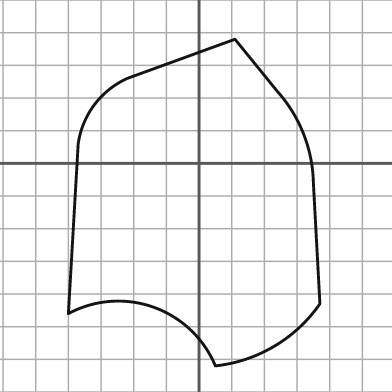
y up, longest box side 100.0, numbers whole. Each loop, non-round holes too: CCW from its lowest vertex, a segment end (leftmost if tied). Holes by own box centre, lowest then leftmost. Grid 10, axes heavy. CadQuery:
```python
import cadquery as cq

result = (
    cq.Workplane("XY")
    .moveTo(5.0, -62.0)
    .threePointArc((23.0, -56.0), (37.0, -43.0))
    .lineTo(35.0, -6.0)
    .threePointArc((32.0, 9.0), (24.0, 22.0))
    .lineTo(11.0, 38.0)
    .lineTo(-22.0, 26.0)
    .threePointArc((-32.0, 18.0), (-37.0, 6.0))
    .lineTo(-40.0, -46.0)
    .threePointArc((-14.0, -44.0), (5.0, -62.0))
    .close()
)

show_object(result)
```